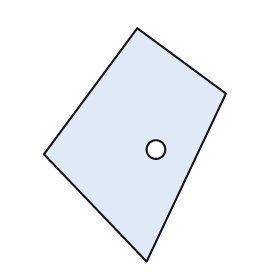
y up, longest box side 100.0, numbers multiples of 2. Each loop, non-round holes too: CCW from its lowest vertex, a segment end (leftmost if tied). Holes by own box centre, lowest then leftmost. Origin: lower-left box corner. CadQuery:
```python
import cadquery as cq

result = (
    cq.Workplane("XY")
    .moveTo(44.0, 0.0)
    .lineTo(78.0, 72.0)
    .lineTo(40.0, 100.0)
    .lineTo(0.0, 46.0)
    .close()
    .moveTo(48.0, 48.0)
    .circle(4.0)
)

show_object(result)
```